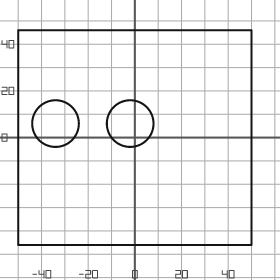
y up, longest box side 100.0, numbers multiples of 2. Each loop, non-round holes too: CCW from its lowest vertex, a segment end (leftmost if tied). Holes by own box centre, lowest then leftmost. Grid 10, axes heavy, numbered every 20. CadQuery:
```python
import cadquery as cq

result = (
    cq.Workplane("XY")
    .moveTo(-50.0, -46.0)
    .lineTo(50.0, -46.0)
    .lineTo(50.0, 46.0)
    .lineTo(-50.0, 46.0)
    .close()
    .moveTo(-34.0, 6.0)
    .circle(10.0)
    .moveTo(-2.0, 6.0)
    .circle(10.0)
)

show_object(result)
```